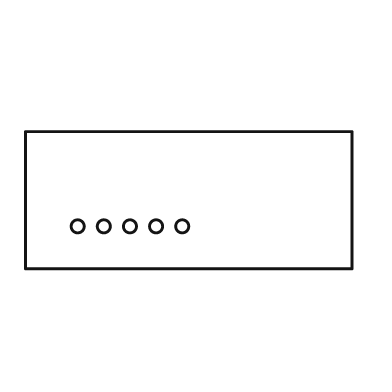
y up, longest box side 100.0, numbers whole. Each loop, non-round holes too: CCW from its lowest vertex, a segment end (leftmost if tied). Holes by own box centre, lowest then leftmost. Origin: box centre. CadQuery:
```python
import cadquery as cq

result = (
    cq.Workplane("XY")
    .moveTo(-50.0, -21.0)
    .lineTo(50.0, -21.0)
    .lineTo(50.0, 21.0)
    .lineTo(-50.0, 21.0)
    .close()
    .moveTo(-34.0, -8.0)
    .circle(2.0)
    .moveTo(-26.0, -8.0)
    .circle(2.0)
    .moveTo(-18.0, -8.0)
    .circle(2.0)
    .moveTo(-10.0, -8.0)
    .circle(2.0)
    .moveTo(-2.0, -8.0)
    .circle(2.0)
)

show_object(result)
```